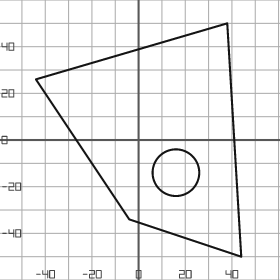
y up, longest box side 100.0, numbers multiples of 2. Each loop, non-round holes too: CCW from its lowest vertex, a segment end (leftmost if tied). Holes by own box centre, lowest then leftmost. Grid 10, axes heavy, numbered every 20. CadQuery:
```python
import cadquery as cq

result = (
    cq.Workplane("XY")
    .moveTo(44.0, -50.0)
    .lineTo(38.0, 50.0)
    .lineTo(-44.0, 26.0)
    .lineTo(-4.0, -34.0)
    .close()
    .moveTo(16.0, -14.0)
    .circle(10.0)
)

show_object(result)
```